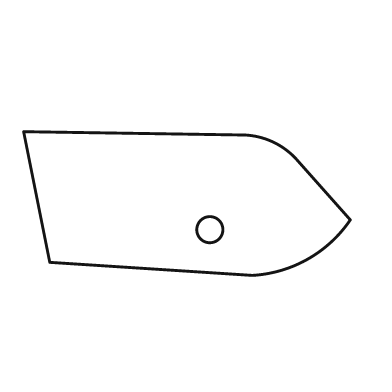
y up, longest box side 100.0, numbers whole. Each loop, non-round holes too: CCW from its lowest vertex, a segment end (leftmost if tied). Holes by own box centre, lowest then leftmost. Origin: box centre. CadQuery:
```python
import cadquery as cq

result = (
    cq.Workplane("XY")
    .moveTo(20.0, -22.0)
    .threePointArc((37.0, -17.0), (50.0, -5.0))
    .lineTo(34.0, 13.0)
    .threePointArc((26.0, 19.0), (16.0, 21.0))
    .lineTo(-50.0, 22.0)
    .lineTo(-42.0, -18.0)
    .close()
    .moveTo(7.0, -8.0)
    .circle(4.0)
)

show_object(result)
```